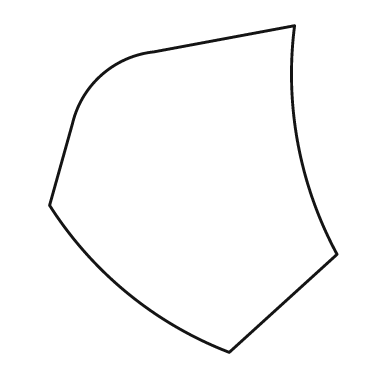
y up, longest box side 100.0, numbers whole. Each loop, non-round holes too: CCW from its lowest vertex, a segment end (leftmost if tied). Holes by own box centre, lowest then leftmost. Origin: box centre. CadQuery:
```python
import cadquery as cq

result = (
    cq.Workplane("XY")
    .moveTo(11.0, -50.0)
    .lineTo(44.0, -20.0)
    .threePointArc((32.0, 14.0), (31.0, 50.0))
    .lineTo(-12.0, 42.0)
    .threePointArc((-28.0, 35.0), (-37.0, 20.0))
    .lineTo(-44.0, -5.0)
    .threePointArc((-20.0, -32.0), (11.0, -50.0))
    .close()
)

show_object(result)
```